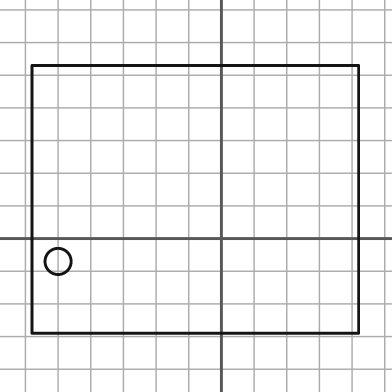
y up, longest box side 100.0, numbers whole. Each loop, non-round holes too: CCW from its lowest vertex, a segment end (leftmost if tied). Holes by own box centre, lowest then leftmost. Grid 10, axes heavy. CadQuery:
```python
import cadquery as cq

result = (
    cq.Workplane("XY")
    .moveTo(-58.0, -29.0)
    .lineTo(42.0, -29.0)
    .lineTo(42.0, 53.0)
    .lineTo(-58.0, 53.0)
    .close()
    .moveTo(-50.0, -7.0)
    .circle(4.0)
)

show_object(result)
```